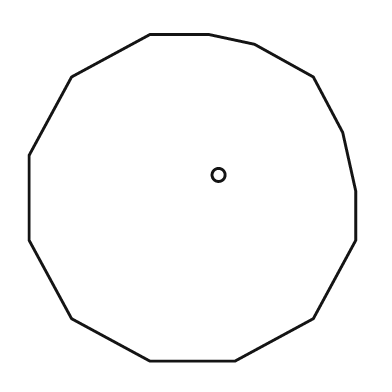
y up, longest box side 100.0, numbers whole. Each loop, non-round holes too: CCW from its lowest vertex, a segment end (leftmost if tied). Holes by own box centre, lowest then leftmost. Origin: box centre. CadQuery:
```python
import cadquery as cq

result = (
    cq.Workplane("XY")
    .moveTo(-13.0, -50.0)
    .lineTo(13.0, -50.0)
    .lineTo(37.0, -37.0)
    .lineTo(50.0, -13.0)
    .lineTo(50.0, 2.0)
    .lineTo(46.0, 20.0)
    .lineTo(37.0, 37.0)
    .lineTo(19.0, 47.0)
    .lineTo(5.0, 50.0)
    .lineTo(-13.0, 50.0)
    .lineTo(-37.0, 37.0)
    .lineTo(-50.0, 13.0)
    .lineTo(-50.0, -13.0)
    .lineTo(-37.0, -37.0)
    .close()
    .moveTo(8.0, 7.0)
    .circle(2.0)
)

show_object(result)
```